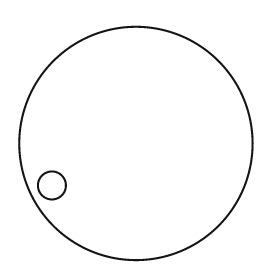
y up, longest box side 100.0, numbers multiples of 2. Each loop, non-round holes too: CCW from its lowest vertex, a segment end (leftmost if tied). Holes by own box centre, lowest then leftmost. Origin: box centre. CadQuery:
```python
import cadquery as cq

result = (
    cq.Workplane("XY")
    .moveTo(0.0, 0.0)
    .circle(50.0)
    .moveTo(-36.0, -18.0)
    .circle(6.0)
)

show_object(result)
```